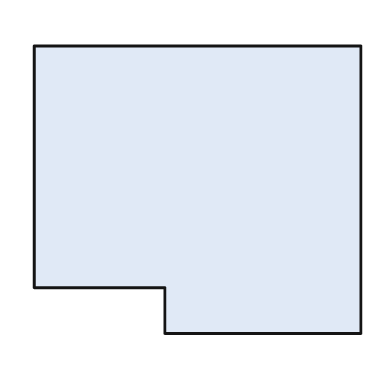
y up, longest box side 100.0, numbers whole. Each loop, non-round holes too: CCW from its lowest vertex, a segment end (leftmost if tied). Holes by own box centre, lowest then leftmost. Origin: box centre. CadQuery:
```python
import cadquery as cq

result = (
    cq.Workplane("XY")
    .moveTo(-10.0, -44.0)
    .lineTo(50.0, -44.0)
    .lineTo(50.0, 44.0)
    .lineTo(-50.0, 44.0)
    .lineTo(-50.0, -30.0)
    .lineTo(-10.0, -30.0)
    .close()
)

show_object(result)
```